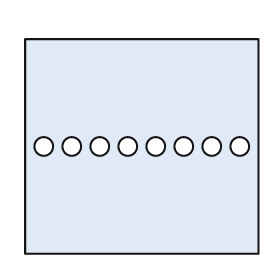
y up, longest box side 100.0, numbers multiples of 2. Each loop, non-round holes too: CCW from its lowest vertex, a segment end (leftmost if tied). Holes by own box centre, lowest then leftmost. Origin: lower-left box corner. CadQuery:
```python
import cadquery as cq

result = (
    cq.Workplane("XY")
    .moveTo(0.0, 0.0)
    .lineTo(100.0, 0.0)
    .lineTo(100.0, 92.0)
    .lineTo(0.0, 92.0)
    .close()
    .moveTo(8.0, 46.0)
    .circle(4.0)
    .moveTo(20.0, 46.0)
    .circle(4.0)
    .moveTo(32.0, 46.0)
    .circle(4.0)
    .moveTo(44.0, 46.0)
    .circle(4.0)
    .moveTo(56.0, 46.0)
    .circle(4.0)
    .moveTo(68.0, 46.0)
    .circle(4.0)
    .moveTo(80.0, 46.0)
    .circle(4.0)
    .moveTo(92.0, 46.0)
    .circle(4.0)
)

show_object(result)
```